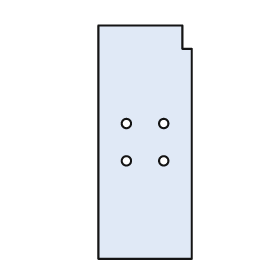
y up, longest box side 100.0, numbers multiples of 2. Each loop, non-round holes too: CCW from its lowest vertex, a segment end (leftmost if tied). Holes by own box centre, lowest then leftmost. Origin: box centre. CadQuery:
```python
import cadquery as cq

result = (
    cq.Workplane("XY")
    .moveTo(-20.0, -50.0)
    .lineTo(20.0, -50.0)
    .lineTo(20.0, 40.0)
    .lineTo(16.0, 40.0)
    .lineTo(16.0, 50.0)
    .lineTo(-20.0, 50.0)
    .close()
    .moveTo(-8.0, -8.0)
    .circle(2.0)
    .moveTo(8.0, -8.0)
    .circle(2.0)
    .moveTo(-8.0, 8.0)
    .circle(2.0)
    .moveTo(8.0, 8.0)
    .circle(2.0)
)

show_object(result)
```